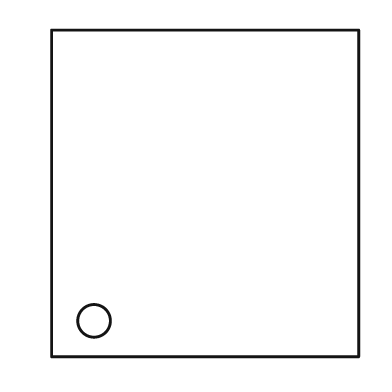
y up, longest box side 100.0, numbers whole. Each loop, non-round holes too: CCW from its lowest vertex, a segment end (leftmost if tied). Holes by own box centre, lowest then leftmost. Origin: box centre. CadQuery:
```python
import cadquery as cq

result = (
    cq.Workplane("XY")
    .moveTo(-47.0, -50.0)
    .lineTo(47.0, -50.0)
    .lineTo(47.0, 50.0)
    .lineTo(-47.0, 50.0)
    .close()
    .moveTo(-34.0, -39.0)
    .circle(5.0)
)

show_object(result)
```